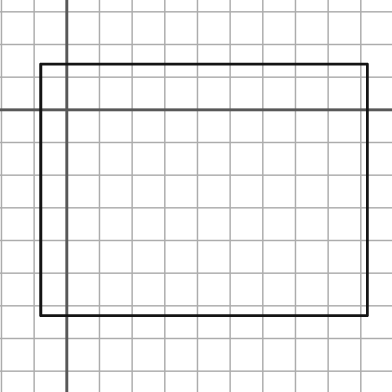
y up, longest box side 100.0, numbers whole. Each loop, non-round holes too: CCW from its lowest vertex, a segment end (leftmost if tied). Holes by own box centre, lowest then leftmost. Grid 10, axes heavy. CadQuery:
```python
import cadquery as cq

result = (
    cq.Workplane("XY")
    .moveTo(-8.0, -63.0)
    .lineTo(92.0, -63.0)
    .lineTo(92.0, 14.0)
    .lineTo(-8.0, 14.0)
    .close()
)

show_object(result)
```